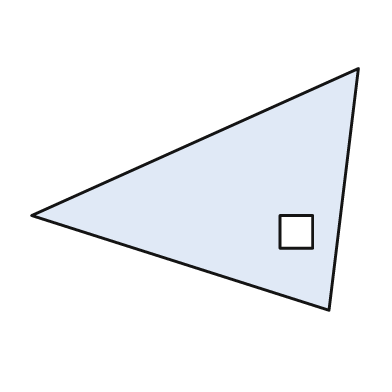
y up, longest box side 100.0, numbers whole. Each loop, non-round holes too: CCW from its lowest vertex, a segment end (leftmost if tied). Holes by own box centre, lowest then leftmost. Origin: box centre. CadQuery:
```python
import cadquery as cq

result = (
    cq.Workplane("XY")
    .moveTo(41.0, -37.0)
    .lineTo(50.0, 37.0)
    .lineTo(-50.0, -8.0)
    .close()
    .moveTo(26.0, -18.0)
    .lineTo(36.0, -18.0)
    .lineTo(36.0, -8.0)
    .lineTo(26.0, -8.0)
    .close()
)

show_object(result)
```